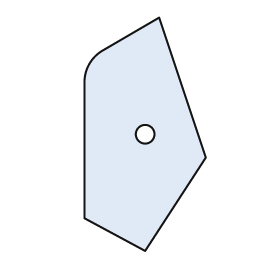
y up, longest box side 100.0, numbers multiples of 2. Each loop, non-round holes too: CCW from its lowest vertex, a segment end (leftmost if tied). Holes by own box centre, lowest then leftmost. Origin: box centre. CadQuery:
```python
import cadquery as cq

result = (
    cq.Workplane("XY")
    .moveTo(0.0, -50.0)
    .lineTo(26.0, -10.0)
    .lineTo(6.0, 50.0)
    .lineTo(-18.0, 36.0)
    .threePointArc((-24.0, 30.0), (-26.0, 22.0))
    .lineTo(-26.0, -36.0)
    .close()
    .moveTo(0.0, 0.0)
    .circle(4.0)
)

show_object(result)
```